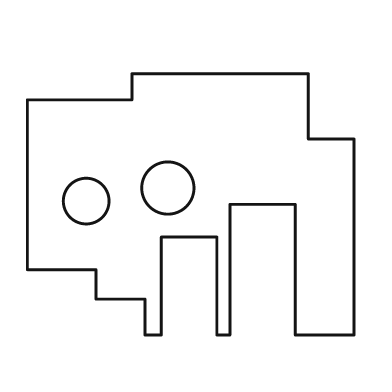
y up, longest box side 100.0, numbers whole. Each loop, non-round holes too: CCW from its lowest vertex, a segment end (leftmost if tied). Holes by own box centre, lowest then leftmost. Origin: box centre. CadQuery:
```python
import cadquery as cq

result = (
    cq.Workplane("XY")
    .moveTo(-14.0, -40.0)
    .lineTo(-9.0, -40.0)
    .lineTo(-9.0, -10.0)
    .lineTo(8.0, -10.0)
    .lineTo(8.0, -40.0)
    .lineTo(12.0, -40.0)
    .lineTo(12.0, 0.0)
    .lineTo(32.0, 0.0)
    .lineTo(32.0, -40.0)
    .lineTo(50.0, -40.0)
    .lineTo(50.0, 20.0)
    .lineTo(36.0, 20.0)
    .lineTo(36.0, 40.0)
    .lineTo(-18.0, 40.0)
    .lineTo(-18.0, 32.0)
    .lineTo(-50.0, 32.0)
    .lineTo(-50.0, -20.0)
    .lineTo(-29.0, -20.0)
    .lineTo(-29.0, -29.0)
    .lineTo(-14.0, -29.0)
    .close()
    .moveTo(-32.0, 1.0)
    .circle(7.0)
    .moveTo(-7.0, 5.0)
    .circle(8.0)
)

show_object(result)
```